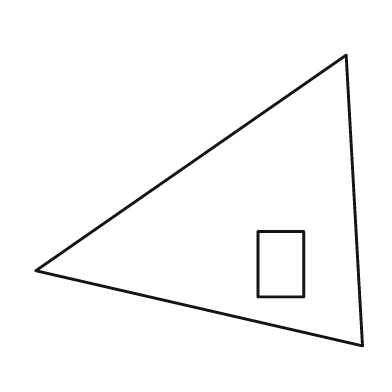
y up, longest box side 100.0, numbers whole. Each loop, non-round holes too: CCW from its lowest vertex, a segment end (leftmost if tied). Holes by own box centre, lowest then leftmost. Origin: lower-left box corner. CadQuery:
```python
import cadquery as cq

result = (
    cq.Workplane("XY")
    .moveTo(100.0, 0.0)
    .lineTo(95.0, 89.0)
    .lineTo(0.0, 23.0)
    .close()
    .moveTo(68.0, 15.0)
    .lineTo(82.0, 15.0)
    .lineTo(82.0, 35.0)
    .lineTo(68.0, 35.0)
    .close()
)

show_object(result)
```